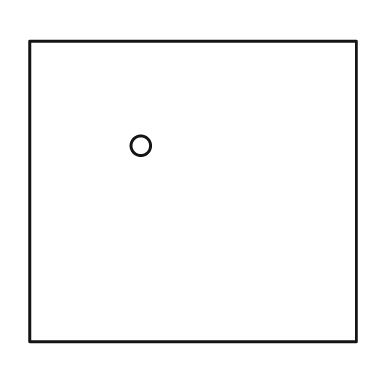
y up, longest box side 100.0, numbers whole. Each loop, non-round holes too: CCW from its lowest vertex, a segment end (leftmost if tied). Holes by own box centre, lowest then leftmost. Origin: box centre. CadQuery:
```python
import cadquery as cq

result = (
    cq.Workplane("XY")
    .moveTo(-50.0, -46.0)
    .lineTo(50.0, -46.0)
    .lineTo(50.0, 46.0)
    .lineTo(-50.0, 46.0)
    .close()
    .moveTo(-16.0, 14.0)
    .circle(3.0)
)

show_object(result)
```